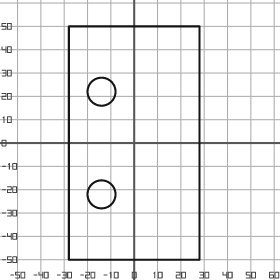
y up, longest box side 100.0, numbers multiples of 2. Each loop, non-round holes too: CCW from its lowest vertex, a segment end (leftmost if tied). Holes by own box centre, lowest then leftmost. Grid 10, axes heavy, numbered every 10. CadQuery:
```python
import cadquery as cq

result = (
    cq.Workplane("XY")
    .moveTo(-28.0, -50.0)
    .lineTo(28.0, -50.0)
    .lineTo(28.0, 50.0)
    .lineTo(-28.0, 50.0)
    .close()
    .moveTo(-14.0, -22.0)
    .circle(6.0)
    .moveTo(-14.0, 22.0)
    .circle(6.0)
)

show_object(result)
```